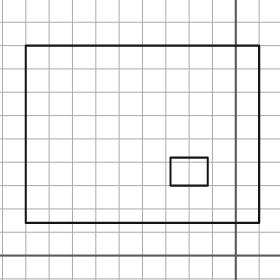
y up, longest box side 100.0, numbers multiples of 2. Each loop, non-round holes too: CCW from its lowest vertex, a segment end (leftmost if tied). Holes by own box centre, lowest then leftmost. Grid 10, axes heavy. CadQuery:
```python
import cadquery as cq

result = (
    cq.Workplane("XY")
    .moveTo(-90.0, 14.0)
    .lineTo(10.0, 14.0)
    .lineTo(10.0, 90.0)
    .lineTo(-90.0, 90.0)
    .close()
    .moveTo(-28.0, 30.0)
    .lineTo(-12.0, 30.0)
    .lineTo(-12.0, 42.0)
    .lineTo(-28.0, 42.0)
    .close()
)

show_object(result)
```